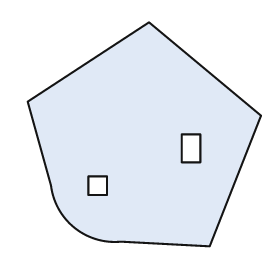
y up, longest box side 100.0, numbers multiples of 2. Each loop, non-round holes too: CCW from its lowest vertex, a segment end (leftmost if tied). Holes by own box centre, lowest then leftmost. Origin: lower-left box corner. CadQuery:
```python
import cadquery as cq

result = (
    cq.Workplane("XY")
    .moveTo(78.0, 0.0)
    .lineTo(100.0, 56.0)
    .lineTo(52.0, 96.0)
    .lineTo(0.0, 62.0)
    .lineTo(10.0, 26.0)
    .threePointArc((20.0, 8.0), (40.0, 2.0))
    .close()
    .moveTo(26.0, 22.0)
    .lineTo(34.0, 22.0)
    .lineTo(34.0, 30.0)
    .lineTo(26.0, 30.0)
    .close()
    .moveTo(66.0, 36.0)
    .lineTo(74.0, 36.0)
    .lineTo(74.0, 48.0)
    .lineTo(66.0, 48.0)
    .close()
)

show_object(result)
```